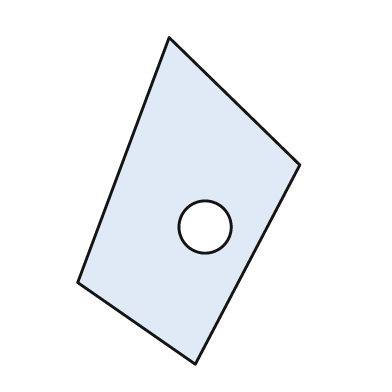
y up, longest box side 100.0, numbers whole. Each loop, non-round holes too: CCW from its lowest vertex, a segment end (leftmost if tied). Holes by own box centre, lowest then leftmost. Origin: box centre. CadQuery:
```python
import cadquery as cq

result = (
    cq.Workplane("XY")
    .moveTo(2.0, -50.0)
    .lineTo(34.0, 11.0)
    .lineTo(-6.0, 50.0)
    .lineTo(-34.0, -25.0)
    .close()
    .moveTo(5.0, -8.0)
    .circle(8.0)
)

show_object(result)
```